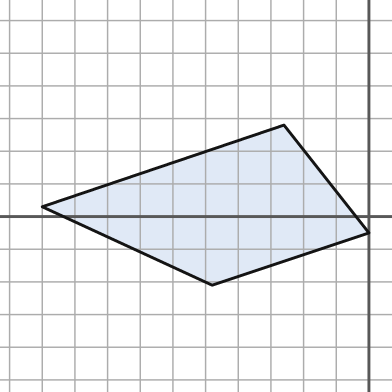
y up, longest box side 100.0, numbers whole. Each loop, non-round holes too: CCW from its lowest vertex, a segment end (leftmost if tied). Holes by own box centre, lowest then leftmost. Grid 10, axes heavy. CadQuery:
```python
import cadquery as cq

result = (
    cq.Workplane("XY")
    .moveTo(-48.0, -21.0)
    .lineTo(0.0, -5.0)
    .lineTo(-26.0, 28.0)
    .lineTo(-100.0, 3.0)
    .close()
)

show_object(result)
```